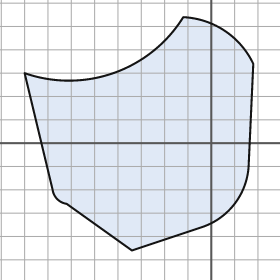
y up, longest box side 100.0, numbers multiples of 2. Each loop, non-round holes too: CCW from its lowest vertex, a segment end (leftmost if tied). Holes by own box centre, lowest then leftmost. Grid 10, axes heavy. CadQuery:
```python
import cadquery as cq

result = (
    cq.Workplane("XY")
    .moveTo(-34.0, -46.0)
    .lineTo(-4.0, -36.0)
    .threePointArc((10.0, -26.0), (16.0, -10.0))
    .lineTo(18.0, 34.0)
    .threePointArc((6.0, 48.0), (-12.0, 54.0))
    .threePointArc((-42.0, 30.0), (-80.0, 30.0))
    .lineTo(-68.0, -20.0)
    .threePointArc((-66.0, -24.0), (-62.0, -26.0))
    .close()
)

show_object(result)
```